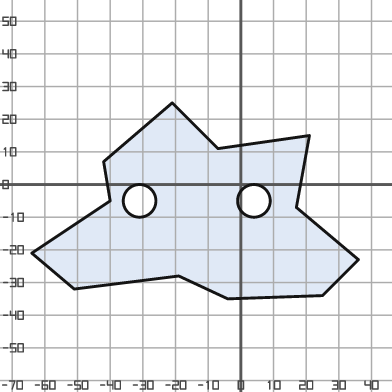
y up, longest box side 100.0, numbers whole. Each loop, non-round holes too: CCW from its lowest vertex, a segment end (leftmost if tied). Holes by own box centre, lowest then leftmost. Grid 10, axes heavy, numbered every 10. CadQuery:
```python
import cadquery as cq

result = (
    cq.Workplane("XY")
    .moveTo(-4.0, -35.0)
    .lineTo(25.0, -34.0)
    .lineTo(36.0, -23.0)
    .lineTo(17.0, -7.0)
    .lineTo(21.0, 15.0)
    .lineTo(-7.0, 11.0)
    .lineTo(-21.0, 25.0)
    .lineTo(-42.0, 7.0)
    .lineTo(-40.0, -5.0)
    .lineTo(-64.0, -21.0)
    .lineTo(-51.0, -32.0)
    .lineTo(-19.0, -28.0)
    .close()
    .moveTo(-31.0, -5.0)
    .circle(5.0)
    .moveTo(4.0, -5.0)
    .circle(5.0)
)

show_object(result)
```